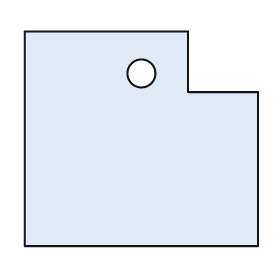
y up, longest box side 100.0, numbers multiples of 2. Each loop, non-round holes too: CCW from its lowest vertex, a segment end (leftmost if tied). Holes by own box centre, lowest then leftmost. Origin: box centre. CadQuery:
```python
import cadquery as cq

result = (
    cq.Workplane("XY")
    .moveTo(-50.0, -46.0)
    .lineTo(50.0, -46.0)
    .lineTo(50.0, 20.0)
    .lineTo(20.0, 20.0)
    .lineTo(20.0, 46.0)
    .lineTo(-50.0, 46.0)
    .close()
    .moveTo(0.0, 28.0)
    .circle(6.0)
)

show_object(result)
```